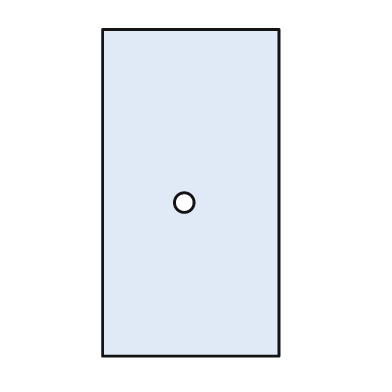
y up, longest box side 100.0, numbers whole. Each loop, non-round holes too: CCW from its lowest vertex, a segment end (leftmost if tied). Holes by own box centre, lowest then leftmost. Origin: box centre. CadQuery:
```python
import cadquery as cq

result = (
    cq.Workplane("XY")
    .moveTo(-27.0, -50.0)
    .lineTo(27.0, -50.0)
    .lineTo(27.0, 50.0)
    .lineTo(-27.0, 50.0)
    .close()
    .moveTo(-2.0, -3.0)
    .circle(3.0)
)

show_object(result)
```